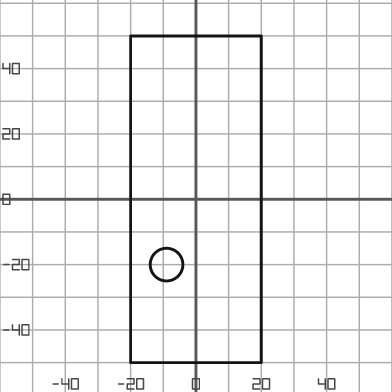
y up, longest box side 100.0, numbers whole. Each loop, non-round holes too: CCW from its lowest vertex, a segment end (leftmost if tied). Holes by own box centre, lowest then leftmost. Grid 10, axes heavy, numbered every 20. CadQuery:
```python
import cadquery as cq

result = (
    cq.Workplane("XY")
    .moveTo(-20.0, -50.0)
    .lineTo(20.0, -50.0)
    .lineTo(20.0, 50.0)
    .lineTo(-20.0, 50.0)
    .close()
    .moveTo(-9.0, -20.0)
    .circle(5.0)
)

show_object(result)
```